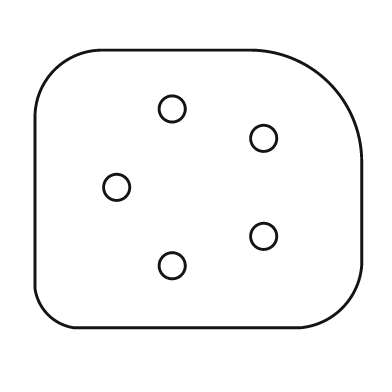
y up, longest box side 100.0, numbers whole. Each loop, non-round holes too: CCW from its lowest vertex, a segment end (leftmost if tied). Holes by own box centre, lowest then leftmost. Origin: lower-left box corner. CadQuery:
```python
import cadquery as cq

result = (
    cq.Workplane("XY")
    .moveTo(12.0, 0.0)
    .lineTo(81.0, 0.0)
    .threePointArc((94.0, 6.0), (100.0, 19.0))
    .lineTo(100.0, 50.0)
    .threePointArc((90.0, 75.0), (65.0, 85.0))
    .lineTo(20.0, 85.0)
    .threePointArc((6.0, 79.0), (0.0, 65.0))
    .lineTo(0.0, 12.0)
    .threePointArc((4.0, 4.0), (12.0, 0.0))
    .close()
    .moveTo(42.0, 19.0)
    .circle(4.0)
    .moveTo(70.0, 28.0)
    .circle(4.0)
    .moveTo(25.0, 43.0)
    .circle(4.0)
    .moveTo(70.0, 58.0)
    .circle(4.0)
    .moveTo(42.0, 67.0)
    .circle(4.0)
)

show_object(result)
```